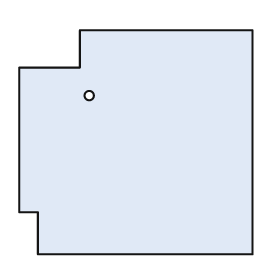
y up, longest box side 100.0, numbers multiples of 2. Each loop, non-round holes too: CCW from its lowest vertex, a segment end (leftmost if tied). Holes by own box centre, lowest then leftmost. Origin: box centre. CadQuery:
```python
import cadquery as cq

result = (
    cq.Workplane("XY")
    .moveTo(-42.0, -48.0)
    .lineTo(50.0, -48.0)
    .lineTo(50.0, 48.0)
    .lineTo(-24.0, 48.0)
    .lineTo(-24.0, 32.0)
    .lineTo(-50.0, 32.0)
    .lineTo(-50.0, -30.0)
    .lineTo(-42.0, -30.0)
    .close()
    .moveTo(-20.0, 20.0)
    .circle(2.0)
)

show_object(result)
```